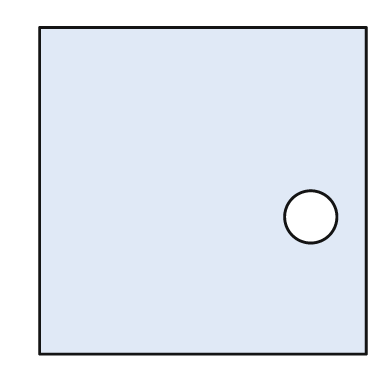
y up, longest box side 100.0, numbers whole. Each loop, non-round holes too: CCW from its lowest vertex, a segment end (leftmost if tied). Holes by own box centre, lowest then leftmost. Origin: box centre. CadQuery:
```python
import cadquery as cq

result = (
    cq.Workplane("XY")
    .moveTo(-50.0, -50.0)
    .lineTo(50.0, -50.0)
    .lineTo(50.0, 50.0)
    .lineTo(-50.0, 50.0)
    .close()
    .moveTo(33.0, -8.0)
    .circle(8.0)
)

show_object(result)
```